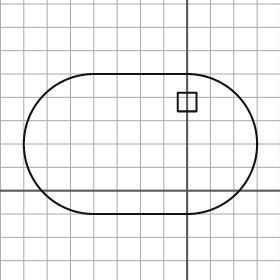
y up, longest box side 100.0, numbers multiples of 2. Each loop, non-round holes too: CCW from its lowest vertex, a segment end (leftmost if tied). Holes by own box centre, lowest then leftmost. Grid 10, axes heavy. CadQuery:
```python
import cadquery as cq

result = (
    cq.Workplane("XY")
    .moveTo(-40.0, -10.0)
    .lineTo(0.0, -10.0)
    .threePointArc((30.0, 20.0), (0.0, 50.0))
    .lineTo(-40.0, 50.0)
    .threePointArc((-70.0, 20.0), (-40.0, -10.0))
    .close()
    .moveTo(-4.0, 34.0)
    .lineTo(4.0, 34.0)
    .lineTo(4.0, 42.0)
    .lineTo(-4.0, 42.0)
    .close()
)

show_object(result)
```